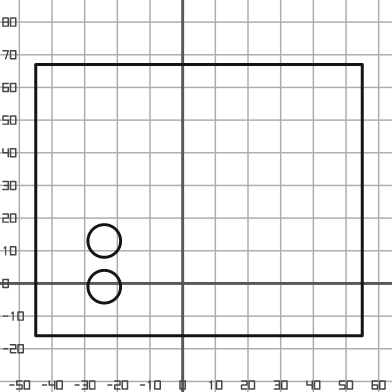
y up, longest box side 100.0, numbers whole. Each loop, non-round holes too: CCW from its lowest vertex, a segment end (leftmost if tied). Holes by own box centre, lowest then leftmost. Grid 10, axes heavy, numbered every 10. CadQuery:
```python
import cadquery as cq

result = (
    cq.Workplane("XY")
    .moveTo(-45.0, -16.0)
    .lineTo(55.0, -16.0)
    .lineTo(55.0, 67.0)
    .lineTo(-45.0, 67.0)
    .close()
    .moveTo(-24.0, -1.0)
    .circle(5.0)
    .moveTo(-24.0, 13.0)
    .circle(5.0)
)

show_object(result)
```